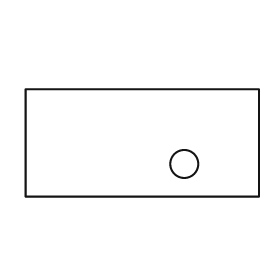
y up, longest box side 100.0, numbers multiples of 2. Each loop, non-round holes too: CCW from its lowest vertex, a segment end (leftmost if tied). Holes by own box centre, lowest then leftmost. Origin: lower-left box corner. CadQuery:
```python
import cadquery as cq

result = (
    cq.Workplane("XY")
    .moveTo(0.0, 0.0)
    .lineTo(100.0, 0.0)
    .lineTo(100.0, 46.0)
    .lineTo(0.0, 46.0)
    .close()
    .moveTo(68.0, 14.0)
    .circle(6.0)
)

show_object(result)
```